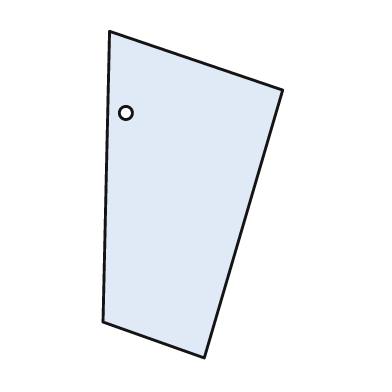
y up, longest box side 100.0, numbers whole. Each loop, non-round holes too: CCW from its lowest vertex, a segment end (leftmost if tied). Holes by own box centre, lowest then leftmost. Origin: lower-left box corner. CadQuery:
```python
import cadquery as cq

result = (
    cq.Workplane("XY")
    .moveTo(31.0, 0.0)
    .lineTo(55.0, 82.0)
    .lineTo(2.0, 100.0)
    .lineTo(0.0, 11.0)
    .close()
    .moveTo(7.0, 75.0)
    .circle(2.0)
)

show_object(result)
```